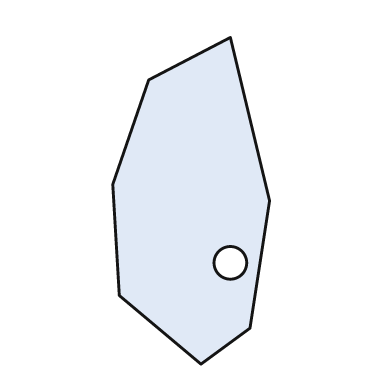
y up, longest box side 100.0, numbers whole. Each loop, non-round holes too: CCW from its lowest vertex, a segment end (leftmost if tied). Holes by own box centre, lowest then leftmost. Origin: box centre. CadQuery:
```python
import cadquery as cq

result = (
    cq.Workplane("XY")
    .moveTo(3.0, -50.0)
    .lineTo(18.0, -39.0)
    .lineTo(24.0, 0.0)
    .lineTo(12.0, 50.0)
    .lineTo(-13.0, 37.0)
    .lineTo(-24.0, 5.0)
    .lineTo(-22.0, -29.0)
    .close()
    .moveTo(12.0, -19.0)
    .circle(5.0)
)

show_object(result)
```